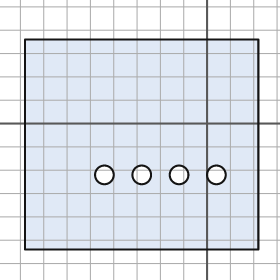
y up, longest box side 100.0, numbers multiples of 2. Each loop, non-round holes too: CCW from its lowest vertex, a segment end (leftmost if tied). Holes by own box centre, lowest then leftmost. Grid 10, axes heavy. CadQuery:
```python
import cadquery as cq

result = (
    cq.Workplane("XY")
    .moveTo(-78.0, -54.0)
    .lineTo(22.0, -54.0)
    .lineTo(22.0, 36.0)
    .lineTo(-78.0, 36.0)
    .close()
    .moveTo(-44.0, -22.0)
    .circle(4.0)
    .moveTo(-28.0, -22.0)
    .circle(4.0)
    .moveTo(-12.0, -22.0)
    .circle(4.0)
    .moveTo(4.0, -22.0)
    .circle(4.0)
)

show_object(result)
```